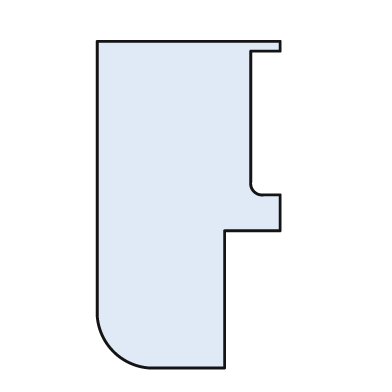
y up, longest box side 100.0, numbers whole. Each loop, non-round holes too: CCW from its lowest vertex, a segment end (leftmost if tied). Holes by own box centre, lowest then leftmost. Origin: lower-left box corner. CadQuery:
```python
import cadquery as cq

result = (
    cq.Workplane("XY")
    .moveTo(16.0, 0.0)
    .lineTo(39.0, 0.0)
    .lineTo(39.0, 42.0)
    .lineTo(56.0, 42.0)
    .lineTo(56.0, 53.0)
    .lineTo(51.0, 53.0)
    .threePointArc((48.0, 54.0), (47.0, 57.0))
    .lineTo(47.0, 97.0)
    .lineTo(56.0, 97.0)
    .lineTo(56.0, 100.0)
    .lineTo(0.0, 100.0)
    .lineTo(0.0, 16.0)
    .threePointArc((5.0, 5.0), (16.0, 0.0))
    .close()
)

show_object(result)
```